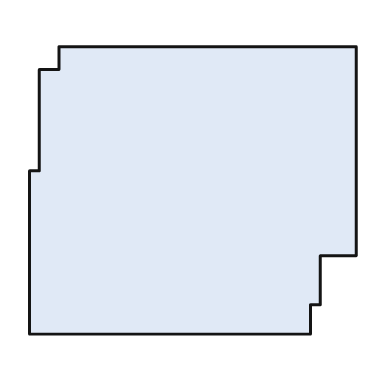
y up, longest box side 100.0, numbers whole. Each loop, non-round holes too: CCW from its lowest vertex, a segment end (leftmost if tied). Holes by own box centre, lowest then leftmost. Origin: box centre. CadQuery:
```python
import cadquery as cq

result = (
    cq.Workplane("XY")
    .moveTo(-50.0, -44.0)
    .lineTo(36.0, -44.0)
    .lineTo(36.0, -35.0)
    .lineTo(39.0, -35.0)
    .lineTo(39.0, -20.0)
    .lineTo(50.0, -20.0)
    .lineTo(50.0, 44.0)
    .lineTo(-41.0, 44.0)
    .lineTo(-41.0, 37.0)
    .lineTo(-47.0, 37.0)
    .lineTo(-47.0, 6.0)
    .lineTo(-50.0, 6.0)
    .close()
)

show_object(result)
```